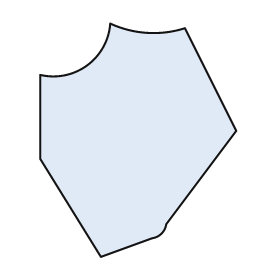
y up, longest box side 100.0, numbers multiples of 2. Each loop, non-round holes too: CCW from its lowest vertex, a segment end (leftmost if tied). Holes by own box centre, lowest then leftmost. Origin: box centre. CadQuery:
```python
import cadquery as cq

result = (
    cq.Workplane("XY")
    .moveTo(-16.0, -50.0)
    .lineTo(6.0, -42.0)
    .threePointArc((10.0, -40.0), (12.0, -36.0))
    .lineTo(42.0, 4.0)
    .lineTo(20.0, 48.0)
    .threePointArc((4.0, 46.0), (-12.0, 50.0))
    .threePointArc((-22.0, 32.0), (-42.0, 28.0))
    .lineTo(-42.0, -8.0)
    .close()
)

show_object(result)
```